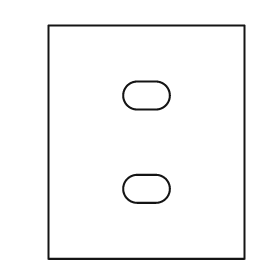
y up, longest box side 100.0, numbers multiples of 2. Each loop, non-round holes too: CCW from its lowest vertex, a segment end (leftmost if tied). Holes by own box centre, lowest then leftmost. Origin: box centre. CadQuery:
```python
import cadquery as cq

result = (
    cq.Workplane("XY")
    .moveTo(-42.0, -50.0)
    .lineTo(42.0, -50.0)
    .lineTo(42.0, 50.0)
    .lineTo(-42.0, 50.0)
    .close()
    .moveTo(-4.0, -26.0)
    .lineTo(4.0, -26.0)
    .threePointArc((10.0, -20.0), (4.0, -14.0))
    .lineTo(-4.0, -14.0)
    .threePointArc((-10.0, -20.0), (-4.0, -26.0))
    .close()
    .moveTo(-4.0, 14.0)
    .lineTo(4.0, 14.0)
    .threePointArc((10.0, 20.0), (4.0, 26.0))
    .lineTo(-4.0, 26.0)
    .threePointArc((-10.0, 20.0), (-4.0, 14.0))
    .close()
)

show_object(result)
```